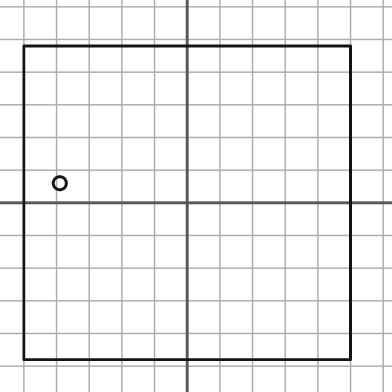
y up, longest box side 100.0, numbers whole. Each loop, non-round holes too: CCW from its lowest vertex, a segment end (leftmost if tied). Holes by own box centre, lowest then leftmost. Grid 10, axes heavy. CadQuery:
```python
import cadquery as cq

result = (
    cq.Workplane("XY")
    .moveTo(-50.0, -48.0)
    .lineTo(50.0, -48.0)
    .lineTo(50.0, 48.0)
    .lineTo(-50.0, 48.0)
    .close()
    .moveTo(-39.0, 6.0)
    .circle(2.0)
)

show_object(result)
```